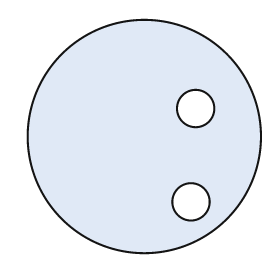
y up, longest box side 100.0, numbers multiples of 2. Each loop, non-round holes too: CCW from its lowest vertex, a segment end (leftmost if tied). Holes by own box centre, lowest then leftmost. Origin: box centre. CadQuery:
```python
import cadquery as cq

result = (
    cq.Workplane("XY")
    .moveTo(0.0, 0.0)
    .circle(50.0)
    .moveTo(20.0, -28.0)
    .circle(8.0)
    .moveTo(22.0, 12.0)
    .circle(8.0)
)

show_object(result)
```